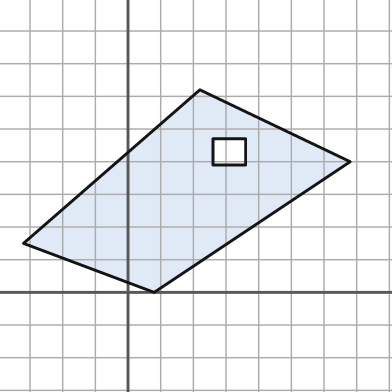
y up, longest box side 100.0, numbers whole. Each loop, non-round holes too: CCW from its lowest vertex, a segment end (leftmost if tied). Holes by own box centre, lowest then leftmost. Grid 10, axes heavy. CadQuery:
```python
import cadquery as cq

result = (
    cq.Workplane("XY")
    .moveTo(8.0, 0.0)
    .lineTo(68.0, 40.0)
    .lineTo(22.0, 62.0)
    .lineTo(-32.0, 15.0)
    .close()
    .moveTo(26.0, 39.0)
    .lineTo(36.0, 39.0)
    .lineTo(36.0, 47.0)
    .lineTo(26.0, 47.0)
    .close()
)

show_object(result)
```